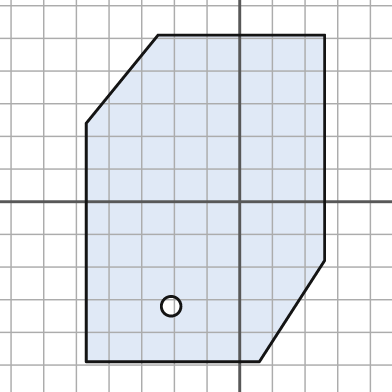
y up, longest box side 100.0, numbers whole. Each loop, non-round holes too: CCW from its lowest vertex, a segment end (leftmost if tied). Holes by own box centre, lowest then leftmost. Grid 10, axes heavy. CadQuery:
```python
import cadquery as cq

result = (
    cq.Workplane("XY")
    .moveTo(-47.0, -49.0)
    .lineTo(6.0, -49.0)
    .lineTo(26.0, -18.0)
    .lineTo(26.0, 51.0)
    .lineTo(-25.0, 51.0)
    .lineTo(-47.0, 24.0)
    .close()
    .moveTo(-21.0, -32.0)
    .circle(3.0)
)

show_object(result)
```